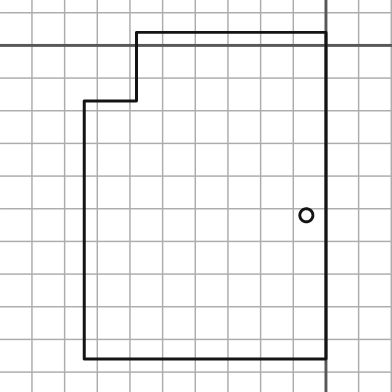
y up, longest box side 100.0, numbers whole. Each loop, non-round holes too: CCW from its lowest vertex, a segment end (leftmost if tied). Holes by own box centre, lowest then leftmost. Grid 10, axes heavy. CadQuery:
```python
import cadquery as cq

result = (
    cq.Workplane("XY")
    .moveTo(-74.0, -96.0)
    .lineTo(0.0, -96.0)
    .lineTo(0.0, 4.0)
    .lineTo(-58.0, 4.0)
    .lineTo(-58.0, -17.0)
    .lineTo(-74.0, -17.0)
    .close()
    .moveTo(-6.0, -52.0)
    .circle(2.0)
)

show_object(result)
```